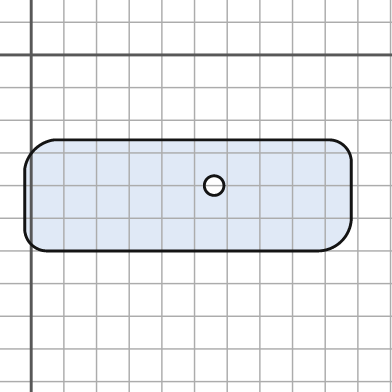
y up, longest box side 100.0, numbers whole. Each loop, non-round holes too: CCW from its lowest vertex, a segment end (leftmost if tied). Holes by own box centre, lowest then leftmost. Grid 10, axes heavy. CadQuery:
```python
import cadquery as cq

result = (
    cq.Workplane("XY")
    .moveTo(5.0, -60.0)
    .lineTo(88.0, -60.0)
    .threePointArc((95.0, -57.0), (98.0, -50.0))
    .lineTo(98.0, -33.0)
    .threePointArc((96.0, -28.0), (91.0, -26.0))
    .lineTo(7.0, -26.0)
    .threePointArc((1.0, -29.0), (-2.0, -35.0))
    .lineTo(-2.0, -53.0)
    .threePointArc((0.0, -58.0), (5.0, -60.0))
    .close()
    .moveTo(56.0, -40.0)
    .circle(3.0)
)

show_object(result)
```